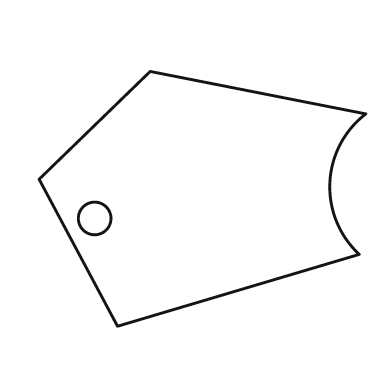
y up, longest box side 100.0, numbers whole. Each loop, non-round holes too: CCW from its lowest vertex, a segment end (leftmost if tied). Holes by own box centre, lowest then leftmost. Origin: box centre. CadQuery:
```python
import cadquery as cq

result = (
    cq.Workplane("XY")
    .moveTo(-26.0, -39.0)
    .lineTo(48.0, -17.0)
    .threePointArc((39.0, 5.0), (50.0, 26.0))
    .lineTo(-16.0, 39.0)
    .lineTo(-50.0, 6.0)
    .close()
    .moveTo(-33.0, -6.0)
    .circle(5.0)
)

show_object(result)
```